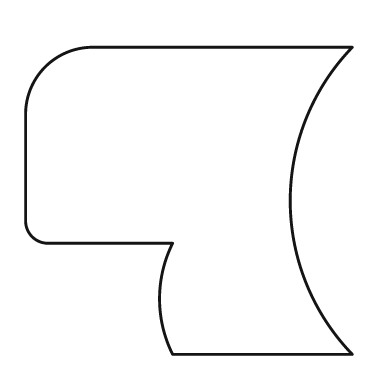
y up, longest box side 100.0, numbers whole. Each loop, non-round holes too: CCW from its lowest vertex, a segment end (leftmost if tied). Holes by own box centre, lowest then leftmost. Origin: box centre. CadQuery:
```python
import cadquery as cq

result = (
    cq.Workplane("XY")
    .moveTo(-5.0, -47.0)
    .lineTo(50.0, -47.0)
    .threePointArc((31.0, 0.0), (50.0, 47.0))
    .lineTo(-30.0, 47.0)
    .threePointArc((-44.0, 41.0), (-50.0, 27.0))
    .lineTo(-50.0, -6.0)
    .threePointArc((-48.0, -11.0), (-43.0, -13.0))
    .lineTo(-5.0, -13.0)
    .threePointArc((-9.0, -30.0), (-5.0, -47.0))
    .close()
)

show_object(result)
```